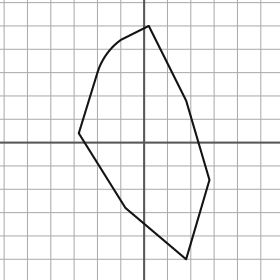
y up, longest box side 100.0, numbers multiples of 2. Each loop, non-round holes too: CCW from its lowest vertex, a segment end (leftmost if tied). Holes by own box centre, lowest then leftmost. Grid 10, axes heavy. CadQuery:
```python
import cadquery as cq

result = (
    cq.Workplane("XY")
    .moveTo(18.0, -50.0)
    .lineTo(28.0, -16.0)
    .lineTo(18.0, 18.0)
    .lineTo(2.0, 50.0)
    .lineTo(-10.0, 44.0)
    .threePointArc((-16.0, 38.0), (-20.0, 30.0))
    .lineTo(-28.0, 4.0)
    .lineTo(-8.0, -28.0)
    .close()
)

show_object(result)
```